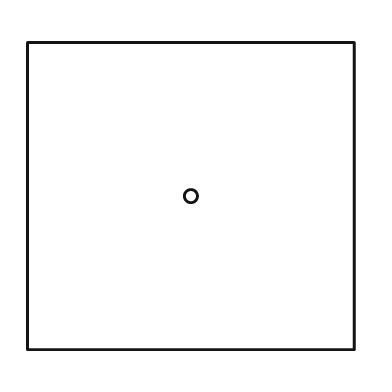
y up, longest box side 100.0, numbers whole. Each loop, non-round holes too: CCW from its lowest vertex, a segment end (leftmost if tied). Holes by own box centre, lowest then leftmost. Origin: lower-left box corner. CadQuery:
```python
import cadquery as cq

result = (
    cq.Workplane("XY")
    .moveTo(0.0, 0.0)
    .lineTo(100.0, 0.0)
    .lineTo(100.0, 94.0)
    .lineTo(0.0, 94.0)
    .close()
    .moveTo(50.0, 47.0)
    .circle(2.0)
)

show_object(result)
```